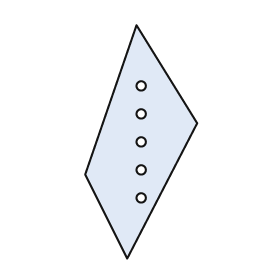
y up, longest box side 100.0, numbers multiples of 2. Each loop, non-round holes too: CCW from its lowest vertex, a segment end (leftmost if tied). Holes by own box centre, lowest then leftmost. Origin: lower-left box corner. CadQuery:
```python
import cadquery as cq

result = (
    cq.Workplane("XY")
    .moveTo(18.0, 0.0)
    .lineTo(48.0, 58.0)
    .lineTo(22.0, 100.0)
    .lineTo(0.0, 36.0)
    .close()
    .moveTo(24.0, 26.0)
    .circle(2.0)
    .moveTo(24.0, 38.0)
    .circle(2.0)
    .moveTo(24.0, 50.0)
    .circle(2.0)
    .moveTo(24.0, 62.0)
    .circle(2.0)
    .moveTo(24.0, 74.0)
    .circle(2.0)
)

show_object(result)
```